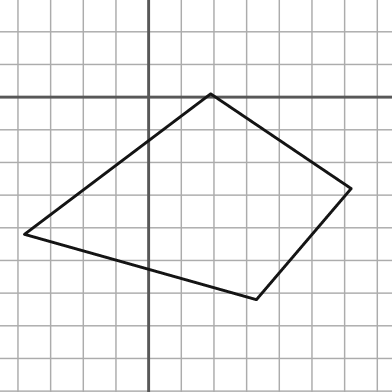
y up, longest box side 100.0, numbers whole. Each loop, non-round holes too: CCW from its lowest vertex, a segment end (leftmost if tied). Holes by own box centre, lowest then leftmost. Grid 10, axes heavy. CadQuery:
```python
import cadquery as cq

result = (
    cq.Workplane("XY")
    .moveTo(33.0, -62.0)
    .lineTo(62.0, -28.0)
    .lineTo(19.0, 1.0)
    .lineTo(-38.0, -42.0)
    .close()
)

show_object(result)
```